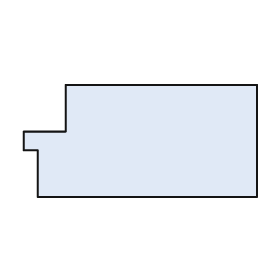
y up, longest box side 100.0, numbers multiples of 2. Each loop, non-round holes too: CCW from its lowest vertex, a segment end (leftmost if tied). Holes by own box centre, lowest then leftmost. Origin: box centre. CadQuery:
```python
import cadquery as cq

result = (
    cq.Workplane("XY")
    .moveTo(-44.0, -24.0)
    .lineTo(50.0, -24.0)
    .lineTo(50.0, 24.0)
    .lineTo(-32.0, 24.0)
    .lineTo(-32.0, 4.0)
    .lineTo(-50.0, 4.0)
    .lineTo(-50.0, -4.0)
    .lineTo(-44.0, -4.0)
    .close()
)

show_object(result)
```